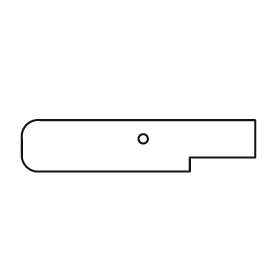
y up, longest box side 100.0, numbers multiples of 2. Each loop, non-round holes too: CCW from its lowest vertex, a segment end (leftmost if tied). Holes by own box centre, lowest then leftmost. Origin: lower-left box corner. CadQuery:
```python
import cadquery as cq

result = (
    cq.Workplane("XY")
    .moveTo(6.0, 0.0)
    .lineTo(72.0, 0.0)
    .lineTo(72.0, 6.0)
    .lineTo(100.0, 6.0)
    .lineTo(100.0, 22.0)
    .lineTo(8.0, 22.0)
    .threePointArc((2.0, 20.0), (0.0, 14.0))
    .lineTo(0.0, 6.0)
    .threePointArc((2.0, 2.0), (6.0, 0.0))
    .close()
    .moveTo(52.0, 14.0)
    .circle(2.0)
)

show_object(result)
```